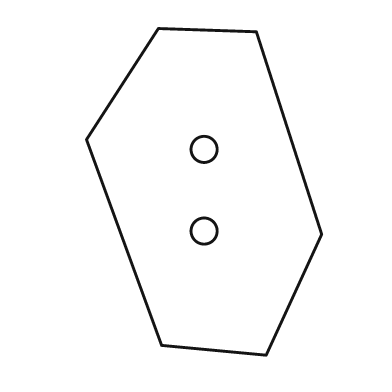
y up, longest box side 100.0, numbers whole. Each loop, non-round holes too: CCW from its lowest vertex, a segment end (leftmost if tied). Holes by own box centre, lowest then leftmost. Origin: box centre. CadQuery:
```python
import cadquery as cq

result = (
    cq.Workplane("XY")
    .moveTo(19.0, -50.0)
    .lineTo(36.0, -13.0)
    .lineTo(16.0, 49.0)
    .lineTo(-14.0, 50.0)
    .lineTo(-36.0, 16.0)
    .lineTo(-13.0, -47.0)
    .close()
    .moveTo(0.0, -12.0)
    .circle(4.0)
    .moveTo(0.0, 13.0)
    .circle(4.0)
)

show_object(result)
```